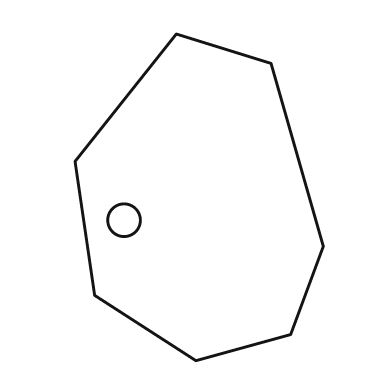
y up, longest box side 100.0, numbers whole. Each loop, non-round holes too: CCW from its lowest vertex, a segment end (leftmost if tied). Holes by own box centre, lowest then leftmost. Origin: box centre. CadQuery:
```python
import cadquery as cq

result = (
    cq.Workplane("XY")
    .moveTo(-1.0, -50.0)
    .lineTo(28.0, -42.0)
    .lineTo(38.0, -15.0)
    .lineTo(22.0, 41.0)
    .lineTo(-7.0, 50.0)
    .lineTo(-38.0, 11.0)
    .lineTo(-32.0, -30.0)
    .close()
    .moveTo(-23.0, -7.0)
    .circle(5.0)
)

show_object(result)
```